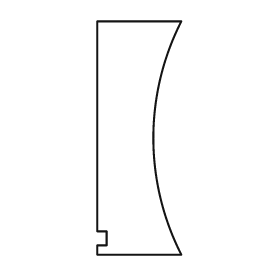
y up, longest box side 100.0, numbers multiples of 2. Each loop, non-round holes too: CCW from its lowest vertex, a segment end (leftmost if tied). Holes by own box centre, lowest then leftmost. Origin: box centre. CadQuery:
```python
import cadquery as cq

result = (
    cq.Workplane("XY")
    .moveTo(-18.0, -50.0)
    .lineTo(18.0, -50.0)
    .threePointArc((6.0, 0.0), (18.0, 50.0))
    .lineTo(-18.0, 50.0)
    .lineTo(-18.0, -40.0)
    .lineTo(-14.0, -40.0)
    .lineTo(-14.0, -46.0)
    .lineTo(-18.0, -46.0)
    .close()
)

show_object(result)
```